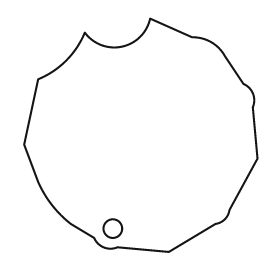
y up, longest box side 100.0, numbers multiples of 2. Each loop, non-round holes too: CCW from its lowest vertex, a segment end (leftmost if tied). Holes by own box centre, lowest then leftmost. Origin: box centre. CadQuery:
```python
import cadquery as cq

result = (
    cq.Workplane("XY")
    .moveTo(12.0, -50.0)
    .lineTo(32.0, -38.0)
    .threePointArc((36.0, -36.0), (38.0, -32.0))
    .lineTo(50.0, -10.0)
    .lineTo(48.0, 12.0)
    .threePointArc((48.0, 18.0), (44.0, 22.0))
    .lineTo(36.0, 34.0)
    .threePointArc((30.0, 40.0), (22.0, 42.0))
    .lineTo(4.0, 50.0)
    .threePointArc((-8.0, 38.0), (-24.0, 44.0))
    .threePointArc((-32.0, 32.0), (-44.0, 24.0))
    .lineTo(-50.0, -4.0)
    .lineTo(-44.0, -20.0)
    .threePointArc((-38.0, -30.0), (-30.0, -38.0))
    .lineTo(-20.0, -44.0)
    .threePointArc((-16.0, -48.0), (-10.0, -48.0))
    .close()
    .moveTo(-12.0, -40.0)
    .circle(4.0)
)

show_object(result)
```